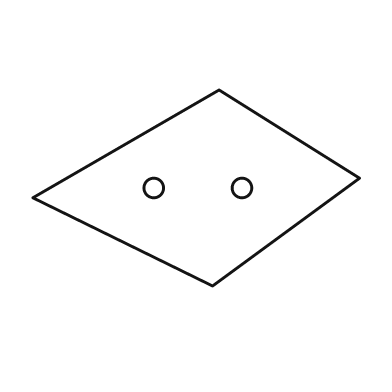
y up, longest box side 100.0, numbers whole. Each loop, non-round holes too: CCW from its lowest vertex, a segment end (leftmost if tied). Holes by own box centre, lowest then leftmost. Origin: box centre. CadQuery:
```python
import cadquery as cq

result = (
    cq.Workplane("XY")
    .moveTo(5.0, -30.0)
    .lineTo(50.0, 3.0)
    .lineTo(7.0, 30.0)
    .lineTo(-50.0, -3.0)
    .close()
    .moveTo(-13.0, 0.0)
    .circle(3.0)
    .moveTo(14.0, 0.0)
    .circle(3.0)
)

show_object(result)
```